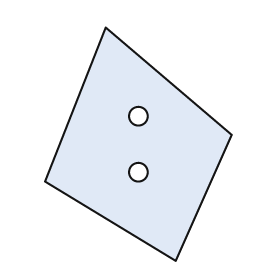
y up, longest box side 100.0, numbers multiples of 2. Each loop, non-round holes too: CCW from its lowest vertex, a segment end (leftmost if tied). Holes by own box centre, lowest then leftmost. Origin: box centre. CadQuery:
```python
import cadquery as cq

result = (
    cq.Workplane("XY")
    .moveTo(16.0, -50.0)
    .lineTo(40.0, 4.0)
    .lineTo(-14.0, 50.0)
    .lineTo(-40.0, -16.0)
    .close()
    .moveTo(0.0, -12.0)
    .circle(4.0)
    .moveTo(0.0, 12.0)
    .circle(4.0)
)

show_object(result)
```